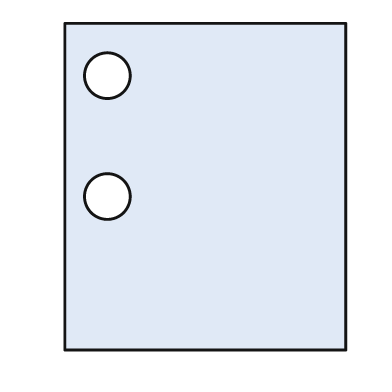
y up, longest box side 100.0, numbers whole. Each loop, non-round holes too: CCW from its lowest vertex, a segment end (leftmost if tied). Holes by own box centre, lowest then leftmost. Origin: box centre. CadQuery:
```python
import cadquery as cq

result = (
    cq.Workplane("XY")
    .moveTo(-43.0, -50.0)
    .lineTo(43.0, -50.0)
    .lineTo(43.0, 50.0)
    .lineTo(-43.0, 50.0)
    .close()
    .moveTo(-30.0, -3.0)
    .circle(7.0)
    .moveTo(-30.0, 34.0)
    .circle(7.0)
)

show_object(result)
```